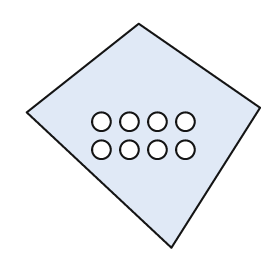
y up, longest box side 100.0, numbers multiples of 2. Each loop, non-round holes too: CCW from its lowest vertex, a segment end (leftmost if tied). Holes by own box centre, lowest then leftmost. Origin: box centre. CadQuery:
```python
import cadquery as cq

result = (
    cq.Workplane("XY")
    .moveTo(12.0, -48.0)
    .lineTo(50.0, 12.0)
    .lineTo(-2.0, 48.0)
    .lineTo(-50.0, 10.0)
    .close()
    .moveTo(-18.0, -6.0)
    .circle(4.0)
    .moveTo(-6.0, -6.0)
    .circle(4.0)
    .moveTo(6.0, -6.0)
    .circle(4.0)
    .moveTo(18.0, -6.0)
    .circle(4.0)
    .moveTo(-18.0, 6.0)
    .circle(4.0)
    .moveTo(-6.0, 6.0)
    .circle(4.0)
    .moveTo(6.0, 6.0)
    .circle(4.0)
    .moveTo(18.0, 6.0)
    .circle(4.0)
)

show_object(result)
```